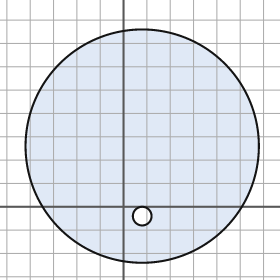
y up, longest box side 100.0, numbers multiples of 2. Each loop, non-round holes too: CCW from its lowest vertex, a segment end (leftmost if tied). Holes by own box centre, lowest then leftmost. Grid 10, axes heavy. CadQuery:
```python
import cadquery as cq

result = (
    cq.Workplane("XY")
    .moveTo(8.0, 26.0)
    .circle(50.0)
    .moveTo(8.0, -4.0)
    .circle(4.0)
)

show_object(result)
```